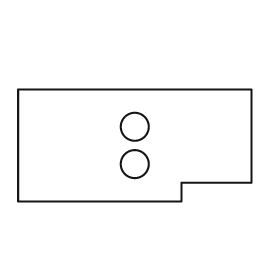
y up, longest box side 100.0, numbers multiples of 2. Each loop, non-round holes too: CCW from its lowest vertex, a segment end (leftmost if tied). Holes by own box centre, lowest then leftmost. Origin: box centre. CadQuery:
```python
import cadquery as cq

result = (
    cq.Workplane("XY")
    .moveTo(-50.0, -24.0)
    .lineTo(20.0, -24.0)
    .lineTo(20.0, -16.0)
    .lineTo(50.0, -16.0)
    .lineTo(50.0, 24.0)
    .lineTo(-50.0, 24.0)
    .close()
    .moveTo(0.0, -8.0)
    .circle(6.0)
    .moveTo(0.0, 8.0)
    .circle(6.0)
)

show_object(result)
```